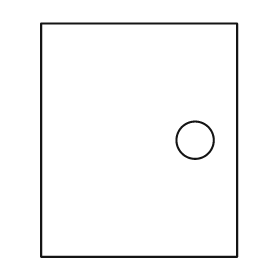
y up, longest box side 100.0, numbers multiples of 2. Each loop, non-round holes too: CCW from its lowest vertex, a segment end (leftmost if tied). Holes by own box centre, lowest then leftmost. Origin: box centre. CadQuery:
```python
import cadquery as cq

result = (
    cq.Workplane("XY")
    .moveTo(-42.0, -50.0)
    .lineTo(42.0, -50.0)
    .lineTo(42.0, 50.0)
    .lineTo(-42.0, 50.0)
    .close()
    .moveTo(24.0, 0.0)
    .circle(8.0)
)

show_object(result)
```